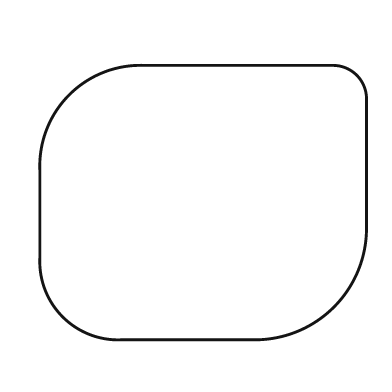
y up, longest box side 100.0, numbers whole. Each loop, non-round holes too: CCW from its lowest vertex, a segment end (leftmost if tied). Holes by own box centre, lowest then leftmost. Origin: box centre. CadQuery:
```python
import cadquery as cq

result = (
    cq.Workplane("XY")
    .moveTo(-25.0, -42.0)
    .lineTo(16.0, -42.0)
    .threePointArc((40.0, -32.0), (50.0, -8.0))
    .lineTo(50.0, 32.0)
    .threePointArc((47.0, 39.0), (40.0, 42.0))
    .lineTo(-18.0, 42.0)
    .threePointArc((-41.0, 33.0), (-50.0, 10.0))
    .lineTo(-50.0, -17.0)
    .threePointArc((-43.0, -35.0), (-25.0, -42.0))
    .close()
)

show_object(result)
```